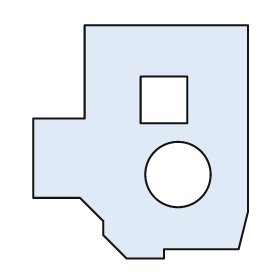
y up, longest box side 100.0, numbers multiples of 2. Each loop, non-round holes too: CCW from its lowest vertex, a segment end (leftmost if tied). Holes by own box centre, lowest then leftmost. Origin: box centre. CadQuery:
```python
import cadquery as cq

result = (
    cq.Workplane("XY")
    .moveTo(-6.0, -50.0)
    .lineTo(10.0, -50.0)
    .lineTo(10.0, -46.0)
    .lineTo(42.0, -46.0)
    .lineTo(46.0, -30.0)
    .lineTo(46.0, 50.0)
    .lineTo(-24.0, 50.0)
    .lineTo(-24.0, 10.0)
    .lineTo(-46.0, 10.0)
    .lineTo(-46.0, -24.0)
    .lineTo(-26.0, -24.0)
    .lineTo(-16.0, -34.0)
    .lineTo(-16.0, -40.0)
    .close()
    .moveTo(16.0, -14.0)
    .circle(14.0)
    .moveTo(0.0, 8.0)
    .lineTo(20.0, 8.0)
    .lineTo(20.0, 28.0)
    .lineTo(0.0, 28.0)
    .close()
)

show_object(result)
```